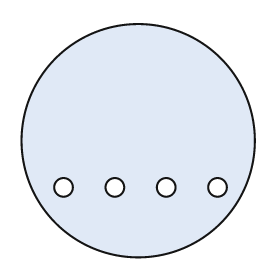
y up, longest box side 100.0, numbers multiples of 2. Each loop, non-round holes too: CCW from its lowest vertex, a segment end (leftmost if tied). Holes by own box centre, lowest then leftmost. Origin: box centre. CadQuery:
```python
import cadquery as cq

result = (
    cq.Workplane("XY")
    .moveTo(0.0, 0.0)
    .circle(50.0)
    .moveTo(-32.0, -20.0)
    .circle(4.0)
    .moveTo(-10.0, -20.0)
    .circle(4.0)
    .moveTo(12.0, -20.0)
    .circle(4.0)
    .moveTo(34.0, -20.0)
    .circle(4.0)
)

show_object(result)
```